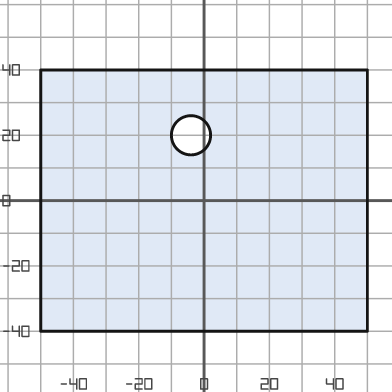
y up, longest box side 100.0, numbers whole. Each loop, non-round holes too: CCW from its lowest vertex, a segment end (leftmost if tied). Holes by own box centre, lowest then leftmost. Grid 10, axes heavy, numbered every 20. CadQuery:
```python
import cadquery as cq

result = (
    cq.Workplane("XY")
    .moveTo(-50.0, -40.0)
    .lineTo(50.0, -40.0)
    .lineTo(50.0, 40.0)
    .lineTo(-50.0, 40.0)
    .close()
    .moveTo(-4.0, 20.0)
    .circle(6.0)
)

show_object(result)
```